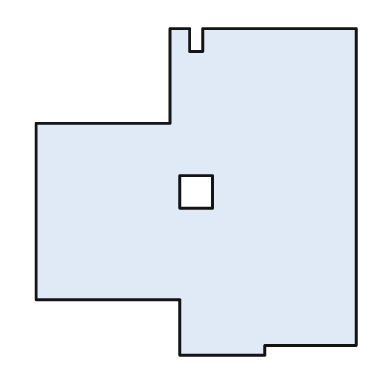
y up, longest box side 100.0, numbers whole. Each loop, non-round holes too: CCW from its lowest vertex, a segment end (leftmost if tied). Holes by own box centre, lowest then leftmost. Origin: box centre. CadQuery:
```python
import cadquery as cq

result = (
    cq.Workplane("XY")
    .moveTo(-5.0, -50.0)
    .lineTo(21.0, -50.0)
    .lineTo(21.0, -47.0)
    .lineTo(49.0, -47.0)
    .lineTo(49.0, 50.0)
    .lineTo(2.0, 50.0)
    .lineTo(2.0, 43.0)
    .lineTo(-2.0, 43.0)
    .lineTo(-2.0, 50.0)
    .lineTo(-8.0, 50.0)
    .lineTo(-8.0, 21.0)
    .lineTo(-49.0, 21.0)
    .lineTo(-49.0, -33.0)
    .lineTo(-5.0, -33.0)
    .close()
    .moveTo(-5.0, -5.0)
    .lineTo(5.0, -5.0)
    .lineTo(5.0, 5.0)
    .lineTo(-5.0, 5.0)
    .close()
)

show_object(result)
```